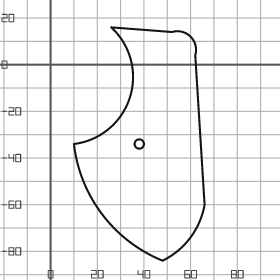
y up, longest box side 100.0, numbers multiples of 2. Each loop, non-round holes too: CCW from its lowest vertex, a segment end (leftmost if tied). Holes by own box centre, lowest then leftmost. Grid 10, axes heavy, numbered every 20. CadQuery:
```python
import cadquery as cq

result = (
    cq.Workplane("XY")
    .moveTo(48.0, -84.0)
    .threePointArc((60.0, -74.0), (66.0, -60.0))
    .lineTo(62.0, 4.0)
    .threePointArc((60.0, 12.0), (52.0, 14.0))
    .lineTo(26.0, 16.0)
    .threePointArc((34.0, -14.0), (10.0, -34.0))
    .threePointArc((22.0, -64.0), (48.0, -84.0))
    .close()
    .moveTo(38.0, -34.0)
    .circle(2.0)
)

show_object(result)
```